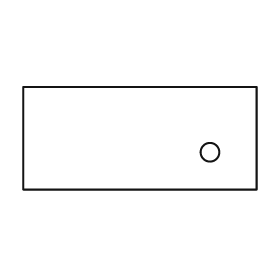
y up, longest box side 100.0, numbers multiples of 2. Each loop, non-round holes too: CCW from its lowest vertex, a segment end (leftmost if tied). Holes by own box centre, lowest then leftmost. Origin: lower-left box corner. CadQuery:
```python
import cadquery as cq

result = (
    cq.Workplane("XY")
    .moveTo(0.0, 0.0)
    .lineTo(100.0, 0.0)
    .lineTo(100.0, 44.0)
    .lineTo(0.0, 44.0)
    .close()
    .moveTo(80.0, 16.0)
    .circle(4.0)
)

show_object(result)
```